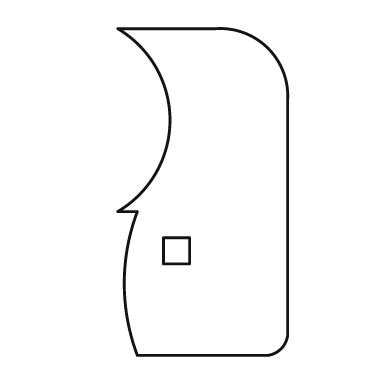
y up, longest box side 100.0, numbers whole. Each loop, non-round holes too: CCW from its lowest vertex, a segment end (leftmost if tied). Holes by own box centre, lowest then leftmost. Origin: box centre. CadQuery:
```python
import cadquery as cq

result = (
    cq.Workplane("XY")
    .moveTo(-20.0, -50.0)
    .lineTo(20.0, -50.0)
    .threePointArc((24.0, -48.0), (26.0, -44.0))
    .lineTo(26.0, 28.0)
    .threePointArc((20.0, 44.0), (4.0, 50.0))
    .lineTo(-26.0, 50.0)
    .threePointArc((-10.0, 22.0), (-26.0, -6.0))
    .lineTo(-20.0, -6.0)
    .threePointArc((-24.0, -28.0), (-20.0, -50.0))
    .close()
    .moveTo(-12.0, -22.0)
    .lineTo(-4.0, -22.0)
    .lineTo(-4.0, -14.0)
    .lineTo(-12.0, -14.0)
    .close()
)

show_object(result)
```